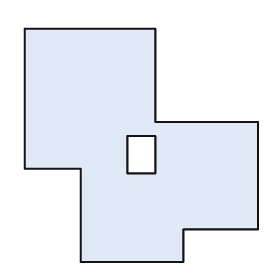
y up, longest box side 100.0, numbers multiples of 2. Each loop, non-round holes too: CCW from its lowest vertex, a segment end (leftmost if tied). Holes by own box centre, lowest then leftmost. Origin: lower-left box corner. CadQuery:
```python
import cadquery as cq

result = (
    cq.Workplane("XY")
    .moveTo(24.0, 0.0)
    .lineTo(68.0, 0.0)
    .lineTo(68.0, 14.0)
    .lineTo(100.0, 14.0)
    .lineTo(100.0, 60.0)
    .lineTo(56.0, 60.0)
    .lineTo(56.0, 100.0)
    .lineTo(0.0, 100.0)
    .lineTo(0.0, 40.0)
    .lineTo(24.0, 40.0)
    .close()
    .moveTo(44.0, 38.0)
    .lineTo(56.0, 38.0)
    .lineTo(56.0, 54.0)
    .lineTo(44.0, 54.0)
    .close()
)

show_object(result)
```